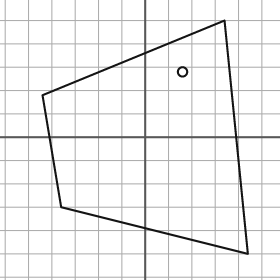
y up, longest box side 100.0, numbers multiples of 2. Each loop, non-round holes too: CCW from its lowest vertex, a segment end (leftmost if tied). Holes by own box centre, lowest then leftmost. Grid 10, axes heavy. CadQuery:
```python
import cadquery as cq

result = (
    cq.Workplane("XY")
    .moveTo(44.0, -50.0)
    .lineTo(34.0, 50.0)
    .lineTo(-44.0, 18.0)
    .lineTo(-36.0, -30.0)
    .close()
    .moveTo(16.0, 28.0)
    .circle(2.0)
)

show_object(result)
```